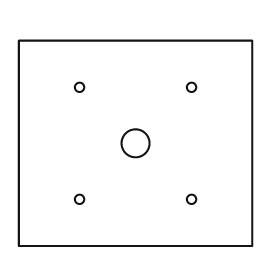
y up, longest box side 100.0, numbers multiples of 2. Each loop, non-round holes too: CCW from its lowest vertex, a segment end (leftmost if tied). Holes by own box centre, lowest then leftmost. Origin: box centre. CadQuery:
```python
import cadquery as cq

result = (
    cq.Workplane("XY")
    .moveTo(-50.0, -44.0)
    .lineTo(50.0, -44.0)
    .lineTo(50.0, 44.0)
    .lineTo(-50.0, 44.0)
    .close()
    .moveTo(-24.0, -24.0)
    .circle(2.0)
    .moveTo(24.0, -24.0)
    .circle(2.0)
    .moveTo(0.0, 0.0)
    .circle(6.0)
    .moveTo(-24.0, 24.0)
    .circle(2.0)
    .moveTo(24.0, 24.0)
    .circle(2.0)
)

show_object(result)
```